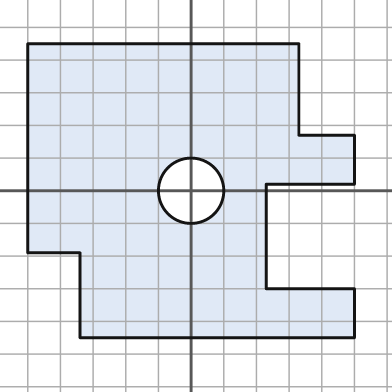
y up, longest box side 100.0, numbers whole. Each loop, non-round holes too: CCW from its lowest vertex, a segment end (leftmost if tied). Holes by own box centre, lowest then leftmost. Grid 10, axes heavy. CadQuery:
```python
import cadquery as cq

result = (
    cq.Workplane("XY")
    .moveTo(-34.0, -45.0)
    .lineTo(50.0, -45.0)
    .lineTo(50.0, -30.0)
    .lineTo(23.0, -30.0)
    .lineTo(23.0, 2.0)
    .lineTo(50.0, 2.0)
    .lineTo(50.0, 17.0)
    .lineTo(33.0, 17.0)
    .lineTo(33.0, 45.0)
    .lineTo(-50.0, 45.0)
    .lineTo(-50.0, -19.0)
    .lineTo(-34.0, -19.0)
    .close()
    .moveTo(0.0, 0.0)
    .circle(10.0)
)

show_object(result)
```